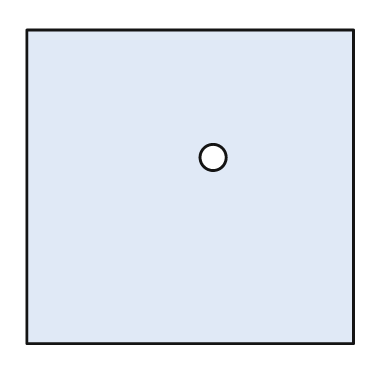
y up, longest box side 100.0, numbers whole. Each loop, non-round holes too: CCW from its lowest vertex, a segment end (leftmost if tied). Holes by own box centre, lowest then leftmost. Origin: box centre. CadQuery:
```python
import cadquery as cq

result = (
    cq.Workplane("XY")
    .moveTo(-50.0, -48.0)
    .lineTo(50.0, -48.0)
    .lineTo(50.0, 48.0)
    .lineTo(-50.0, 48.0)
    .close()
    .moveTo(7.0, 9.0)
    .circle(4.0)
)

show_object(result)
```